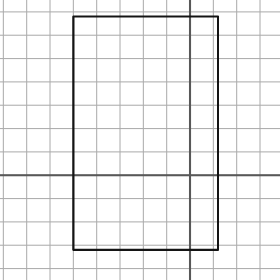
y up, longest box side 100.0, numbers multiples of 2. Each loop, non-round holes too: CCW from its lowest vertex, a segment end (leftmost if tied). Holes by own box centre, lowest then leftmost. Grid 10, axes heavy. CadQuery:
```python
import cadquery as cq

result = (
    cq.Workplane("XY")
    .moveTo(-50.0, -32.0)
    .lineTo(12.0, -32.0)
    .lineTo(12.0, 68.0)
    .lineTo(-50.0, 68.0)
    .close()
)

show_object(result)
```